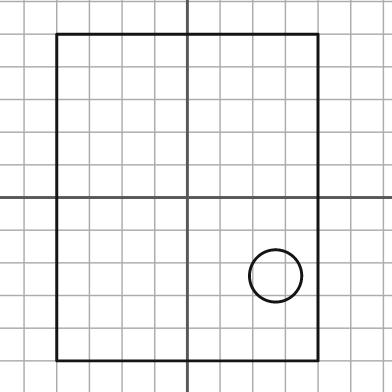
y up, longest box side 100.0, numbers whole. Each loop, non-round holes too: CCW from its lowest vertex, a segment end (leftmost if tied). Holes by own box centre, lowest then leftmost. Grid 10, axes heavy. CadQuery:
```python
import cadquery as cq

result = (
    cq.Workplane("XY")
    .moveTo(-40.0, -50.0)
    .lineTo(40.0, -50.0)
    .lineTo(40.0, 50.0)
    .lineTo(-40.0, 50.0)
    .close()
    .moveTo(27.0, -24.0)
    .circle(8.0)
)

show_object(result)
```